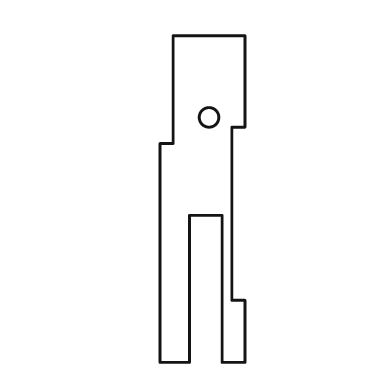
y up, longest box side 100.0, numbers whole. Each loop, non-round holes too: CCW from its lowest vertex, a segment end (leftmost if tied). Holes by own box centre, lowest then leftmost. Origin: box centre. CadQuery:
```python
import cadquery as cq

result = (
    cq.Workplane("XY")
    .moveTo(-13.0, -50.0)
    .lineTo(-4.0, -50.0)
    .lineTo(-4.0, -5.0)
    .lineTo(6.0, -5.0)
    .lineTo(6.0, -50.0)
    .lineTo(13.0, -50.0)
    .lineTo(13.0, -31.0)
    .lineTo(9.0, -31.0)
    .lineTo(9.0, 22.0)
    .lineTo(13.0, 22.0)
    .lineTo(13.0, 50.0)
    .lineTo(-9.0, 50.0)
    .lineTo(-9.0, 17.0)
    .lineTo(-13.0, 17.0)
    .close()
    .moveTo(2.0, 25.0)
    .circle(3.0)
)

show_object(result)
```